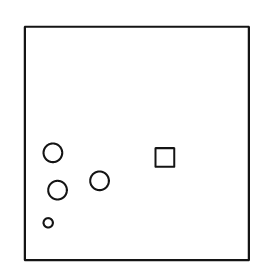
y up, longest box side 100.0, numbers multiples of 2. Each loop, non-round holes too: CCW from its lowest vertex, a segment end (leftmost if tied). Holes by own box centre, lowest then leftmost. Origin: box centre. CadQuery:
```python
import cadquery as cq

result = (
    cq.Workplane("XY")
    .moveTo(-48.0, -50.0)
    .lineTo(48.0, -50.0)
    .lineTo(48.0, 50.0)
    .lineTo(-48.0, 50.0)
    .close()
    .moveTo(-38.0, -34.0)
    .circle(2.0)
    .moveTo(-34.0, -20.0)
    .circle(4.0)
    .moveTo(-16.0, -16.0)
    .circle(4.0)
    .moveTo(8.0, -10.0)
    .lineTo(16.0, -10.0)
    .lineTo(16.0, -2.0)
    .lineTo(8.0, -2.0)
    .close()
    .moveTo(-36.0, -4.0)
    .circle(4.0)
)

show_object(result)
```